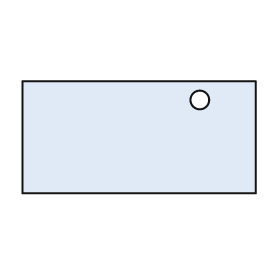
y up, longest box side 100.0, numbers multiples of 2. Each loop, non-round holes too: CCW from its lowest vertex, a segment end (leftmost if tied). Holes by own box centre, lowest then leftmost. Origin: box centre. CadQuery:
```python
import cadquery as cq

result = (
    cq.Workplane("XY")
    .moveTo(-50.0, -24.0)
    .lineTo(50.0, -24.0)
    .lineTo(50.0, 24.0)
    .lineTo(-50.0, 24.0)
    .close()
    .moveTo(26.0, 16.0)
    .circle(4.0)
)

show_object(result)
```